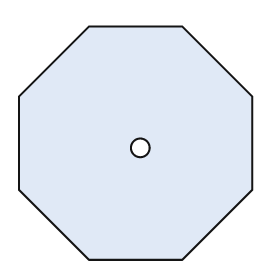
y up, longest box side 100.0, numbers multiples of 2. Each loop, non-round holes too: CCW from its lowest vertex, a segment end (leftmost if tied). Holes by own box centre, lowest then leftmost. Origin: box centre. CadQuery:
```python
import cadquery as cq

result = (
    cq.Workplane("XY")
    .moveTo(-20.0, -50.0)
    .lineTo(20.0, -50.0)
    .lineTo(50.0, -20.0)
    .lineTo(50.0, 20.0)
    .lineTo(20.0, 50.0)
    .lineTo(-20.0, 50.0)
    .lineTo(-50.0, 20.0)
    .lineTo(-50.0, -20.0)
    .close()
    .moveTo(2.0, -2.0)
    .circle(4.0)
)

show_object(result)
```